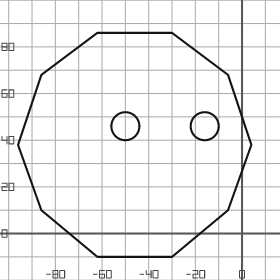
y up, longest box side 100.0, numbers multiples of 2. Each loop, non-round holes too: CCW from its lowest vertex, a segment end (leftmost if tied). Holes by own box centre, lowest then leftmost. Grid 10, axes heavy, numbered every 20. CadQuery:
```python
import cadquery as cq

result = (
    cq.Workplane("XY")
    .moveTo(-62.0, -10.0)
    .lineTo(-30.0, -10.0)
    .lineTo(-6.0, 10.0)
    .lineTo(4.0, 38.0)
    .lineTo(-6.0, 68.0)
    .lineTo(-30.0, 86.0)
    .lineTo(-62.0, 86.0)
    .lineTo(-86.0, 68.0)
    .lineTo(-96.0, 38.0)
    .lineTo(-86.0, 10.0)
    .close()
    .moveTo(-50.0, 46.0)
    .circle(6.0)
    .moveTo(-16.0, 46.0)
    .circle(6.0)
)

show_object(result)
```